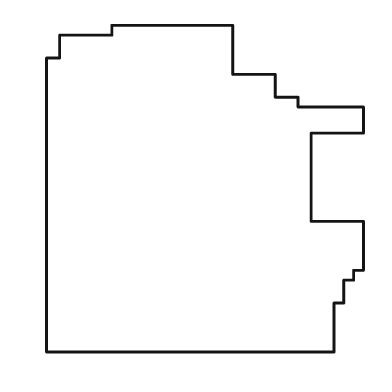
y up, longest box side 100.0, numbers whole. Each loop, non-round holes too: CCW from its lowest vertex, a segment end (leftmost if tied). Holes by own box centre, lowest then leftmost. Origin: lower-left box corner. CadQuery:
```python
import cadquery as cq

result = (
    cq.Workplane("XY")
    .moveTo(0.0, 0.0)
    .lineTo(88.0, 0.0)
    .lineTo(88.0, 15.0)
    .lineTo(91.0, 15.0)
    .lineTo(91.0, 22.0)
    .lineTo(94.0, 22.0)
    .lineTo(94.0, 25.0)
    .lineTo(97.0, 25.0)
    .lineTo(97.0, 40.0)
    .lineTo(81.0, 40.0)
    .lineTo(81.0, 67.0)
    .lineTo(97.0, 67.0)
    .lineTo(97.0, 75.0)
    .lineTo(77.0, 75.0)
    .lineTo(77.0, 78.0)
    .lineTo(70.0, 78.0)
    .lineTo(70.0, 85.0)
    .lineTo(57.0, 85.0)
    .lineTo(57.0, 100.0)
    .lineTo(20.0, 100.0)
    .lineTo(20.0, 97.0)
    .lineTo(4.0, 97.0)
    .lineTo(4.0, 90.0)
    .lineTo(0.0, 90.0)
    .close()
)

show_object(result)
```